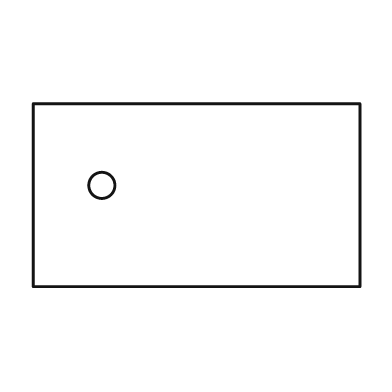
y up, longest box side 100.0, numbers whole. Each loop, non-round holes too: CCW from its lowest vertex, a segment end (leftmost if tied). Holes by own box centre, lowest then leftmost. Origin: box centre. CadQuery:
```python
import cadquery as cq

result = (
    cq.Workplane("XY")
    .moveTo(-50.0, -28.0)
    .lineTo(50.0, -28.0)
    .lineTo(50.0, 28.0)
    .lineTo(-50.0, 28.0)
    .close()
    .moveTo(-29.0, 3.0)
    .circle(4.0)
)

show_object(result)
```